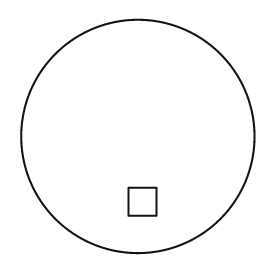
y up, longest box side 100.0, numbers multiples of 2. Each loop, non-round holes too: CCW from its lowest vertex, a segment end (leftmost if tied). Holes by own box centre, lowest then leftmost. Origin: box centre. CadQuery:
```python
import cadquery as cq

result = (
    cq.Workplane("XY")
    .moveTo(0.0, 0.0)
    .circle(50.0)
    .moveTo(-4.0, -34.0)
    .lineTo(8.0, -34.0)
    .lineTo(8.0, -22.0)
    .lineTo(-4.0, -22.0)
    .close()
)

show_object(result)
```